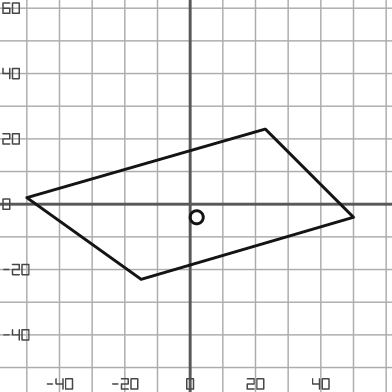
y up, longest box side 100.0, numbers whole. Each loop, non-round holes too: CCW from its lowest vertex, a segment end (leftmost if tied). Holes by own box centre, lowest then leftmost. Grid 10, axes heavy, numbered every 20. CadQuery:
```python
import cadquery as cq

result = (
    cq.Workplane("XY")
    .moveTo(-15.0, -23.0)
    .lineTo(50.0, -4.0)
    .lineTo(23.0, 23.0)
    .lineTo(-50.0, 2.0)
    .close()
    .moveTo(2.0, -4.0)
    .circle(2.0)
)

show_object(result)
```